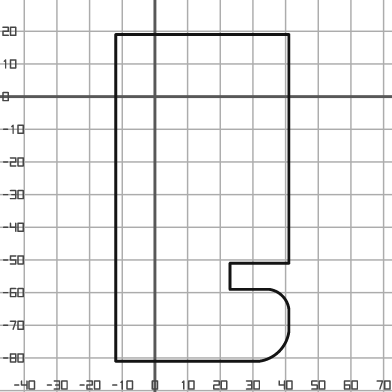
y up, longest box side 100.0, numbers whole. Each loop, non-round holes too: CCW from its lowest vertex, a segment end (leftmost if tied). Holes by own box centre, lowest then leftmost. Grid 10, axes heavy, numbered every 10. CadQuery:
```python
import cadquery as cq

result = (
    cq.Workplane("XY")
    .moveTo(-12.0, -81.0)
    .lineTo(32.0, -81.0)
    .threePointArc((38.0, -78.0), (41.0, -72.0))
    .lineTo(41.0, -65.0)
    .threePointArc((39.0, -61.0), (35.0, -59.0))
    .lineTo(23.0, -59.0)
    .lineTo(23.0, -51.0)
    .lineTo(41.0, -51.0)
    .lineTo(41.0, 19.0)
    .lineTo(-12.0, 19.0)
    .close()
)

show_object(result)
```